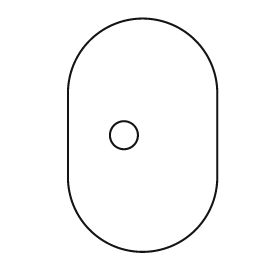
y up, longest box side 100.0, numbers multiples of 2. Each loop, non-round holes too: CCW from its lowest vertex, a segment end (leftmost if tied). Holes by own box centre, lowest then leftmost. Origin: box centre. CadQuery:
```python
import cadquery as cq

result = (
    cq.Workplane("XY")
    .moveTo(-32.0, -18.0)
    .threePointArc((0.0, -50.0), (32.0, -18.0))
    .lineTo(32.0, 18.0)
    .threePointArc((0.0, 50.0), (-32.0, 18.0))
    .close()
    .moveTo(-8.0, 0.0)
    .circle(6.0)
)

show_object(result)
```